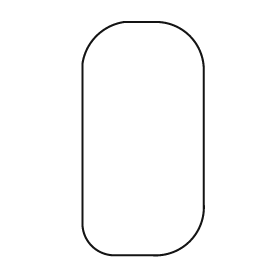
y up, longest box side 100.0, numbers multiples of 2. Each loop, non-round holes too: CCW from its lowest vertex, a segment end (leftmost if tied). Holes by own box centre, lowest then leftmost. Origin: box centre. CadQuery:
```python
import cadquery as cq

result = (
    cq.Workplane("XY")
    .moveTo(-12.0, -50.0)
    .lineTo(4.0, -50.0)
    .threePointArc((20.0, -44.0), (26.0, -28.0))
    .lineTo(26.0, 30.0)
    .threePointArc((20.0, 44.0), (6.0, 50.0))
    .lineTo(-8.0, 50.0)
    .threePointArc((-20.0, 44.0), (-26.0, 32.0))
    .lineTo(-26.0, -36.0)
    .threePointArc((-22.0, -46.0), (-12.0, -50.0))
    .close()
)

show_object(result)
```